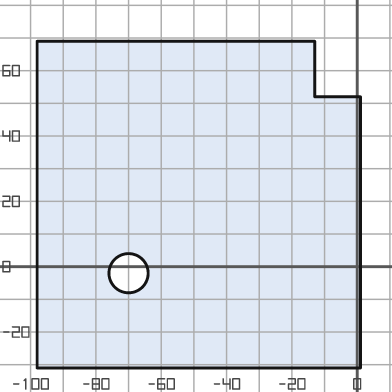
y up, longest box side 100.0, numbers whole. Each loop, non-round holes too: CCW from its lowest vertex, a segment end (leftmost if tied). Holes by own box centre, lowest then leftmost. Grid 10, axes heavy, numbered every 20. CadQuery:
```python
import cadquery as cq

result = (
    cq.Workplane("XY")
    .moveTo(-98.0, -31.0)
    .lineTo(1.0, -31.0)
    .lineTo(1.0, 52.0)
    .lineTo(-13.0, 52.0)
    .lineTo(-13.0, 69.0)
    .lineTo(-98.0, 69.0)
    .close()
    .moveTo(-70.0, -2.0)
    .circle(6.0)
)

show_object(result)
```